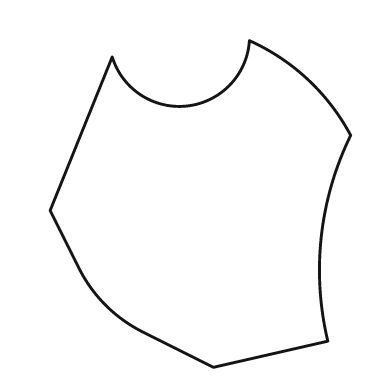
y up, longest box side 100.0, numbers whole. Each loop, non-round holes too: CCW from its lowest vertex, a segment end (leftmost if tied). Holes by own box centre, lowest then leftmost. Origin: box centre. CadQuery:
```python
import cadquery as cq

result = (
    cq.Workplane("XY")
    .moveTo(4.0, -50.0)
    .lineTo(39.0, -42.0)
    .threePointArc((37.0, -10.0), (46.0, 21.0))
    .threePointArc((33.0, 38.0), (15.0, 50.0))
    .threePointArc((-4.0, 30.0), (-27.0, 45.0))
    .lineTo(-46.0, -2.0)
    .lineTo(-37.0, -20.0)
    .threePointArc((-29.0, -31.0), (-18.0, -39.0))
    .close()
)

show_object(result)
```